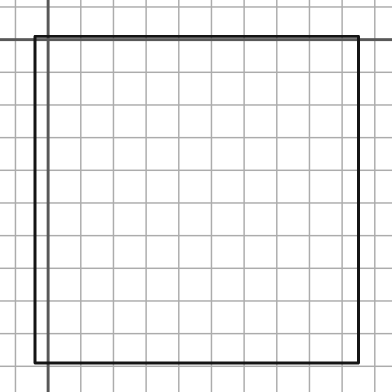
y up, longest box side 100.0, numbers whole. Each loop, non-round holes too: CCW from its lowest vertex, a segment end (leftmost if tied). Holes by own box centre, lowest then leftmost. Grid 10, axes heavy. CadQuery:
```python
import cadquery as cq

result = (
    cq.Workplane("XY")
    .moveTo(-4.0, -99.0)
    .lineTo(95.0, -99.0)
    .lineTo(95.0, 1.0)
    .lineTo(-4.0, 1.0)
    .close()
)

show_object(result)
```